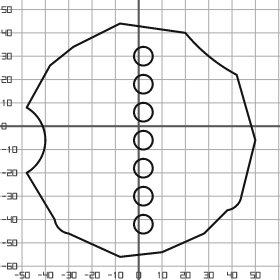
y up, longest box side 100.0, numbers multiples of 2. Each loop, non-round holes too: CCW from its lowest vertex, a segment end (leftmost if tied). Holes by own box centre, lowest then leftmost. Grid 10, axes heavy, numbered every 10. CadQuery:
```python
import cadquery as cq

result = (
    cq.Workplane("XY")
    .moveTo(-8.0, -56.0)
    .lineTo(10.0, -54.0)
    .lineTo(28.0, -46.0)
    .lineTo(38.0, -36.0)
    .threePointArc((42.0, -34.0), (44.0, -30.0))
    .lineTo(50.0, -6.0)
    .lineTo(42.0, 22.0)
    .threePointArc((30.0, 30.0), (20.0, 40.0))
    .lineTo(-8.0, 44.0)
    .lineTo(-28.0, 34.0)
    .lineTo(-38.0, 26.0)
    .lineTo(-48.0, 8.0)
    .threePointArc((-40.0, -6.0), (-48.0, -20.0))
    .lineTo(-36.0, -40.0)
    .threePointArc((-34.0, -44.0), (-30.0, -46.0))
    .close()
    .moveTo(2.0, -42.0)
    .circle(4.0)
    .moveTo(2.0, -30.0)
    .circle(4.0)
    .moveTo(2.0, -18.0)
    .circle(4.0)
    .moveTo(2.0, -6.0)
    .circle(4.0)
    .moveTo(2.0, 6.0)
    .circle(4.0)
    .moveTo(2.0, 18.0)
    .circle(4.0)
    .moveTo(2.0, 30.0)
    .circle(4.0)
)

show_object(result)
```